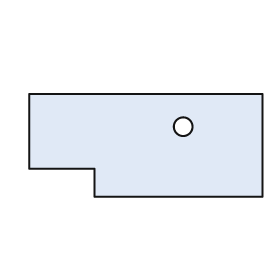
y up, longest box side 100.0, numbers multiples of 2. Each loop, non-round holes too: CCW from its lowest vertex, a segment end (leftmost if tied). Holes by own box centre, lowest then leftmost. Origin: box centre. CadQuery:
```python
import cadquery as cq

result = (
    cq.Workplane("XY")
    .moveTo(-22.0, -22.0)
    .lineTo(50.0, -22.0)
    .lineTo(50.0, 22.0)
    .lineTo(-50.0, 22.0)
    .lineTo(-50.0, -10.0)
    .lineTo(-22.0, -10.0)
    .close()
    .moveTo(16.0, 8.0)
    .circle(4.0)
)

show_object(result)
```